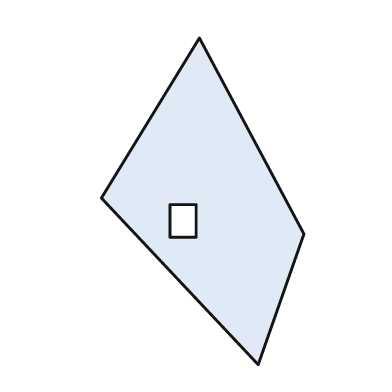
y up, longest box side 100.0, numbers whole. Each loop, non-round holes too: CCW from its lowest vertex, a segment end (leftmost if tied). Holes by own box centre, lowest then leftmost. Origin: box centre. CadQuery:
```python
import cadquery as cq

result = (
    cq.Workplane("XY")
    .moveTo(17.0, -50.0)
    .lineTo(31.0, -10.0)
    .lineTo(-1.0, 50.0)
    .lineTo(-31.0, 1.0)
    .close()
    .moveTo(-10.0, -11.0)
    .lineTo(-2.0, -11.0)
    .lineTo(-2.0, -1.0)
    .lineTo(-10.0, -1.0)
    .close()
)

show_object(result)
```